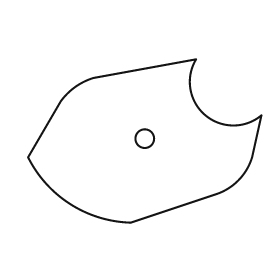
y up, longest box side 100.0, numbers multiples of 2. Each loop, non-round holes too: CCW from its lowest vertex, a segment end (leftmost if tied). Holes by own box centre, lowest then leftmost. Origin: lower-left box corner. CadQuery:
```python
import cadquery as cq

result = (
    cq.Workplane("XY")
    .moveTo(44.0, 0.0)
    .lineTo(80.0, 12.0)
    .threePointArc((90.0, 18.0), (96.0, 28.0))
    .lineTo(100.0, 46.0)
    .threePointArc((76.0, 46.0), (72.0, 70.0))
    .lineTo(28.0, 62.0)
    .threePointArc((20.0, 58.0), (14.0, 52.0))
    .lineTo(0.0, 28.0)
    .threePointArc((18.0, 8.0), (44.0, 0.0))
    .close()
    .moveTo(50.0, 36.0)
    .circle(4.0)
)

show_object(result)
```